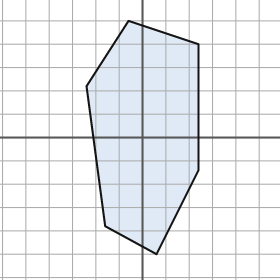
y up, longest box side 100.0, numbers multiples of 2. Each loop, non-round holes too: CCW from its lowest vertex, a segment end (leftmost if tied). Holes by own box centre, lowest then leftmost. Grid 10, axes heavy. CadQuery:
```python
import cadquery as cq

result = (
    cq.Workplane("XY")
    .moveTo(6.0, -50.0)
    .lineTo(24.0, -14.0)
    .lineTo(24.0, 40.0)
    .lineTo(-6.0, 50.0)
    .lineTo(-24.0, 22.0)
    .lineTo(-16.0, -38.0)
    .close()
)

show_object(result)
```